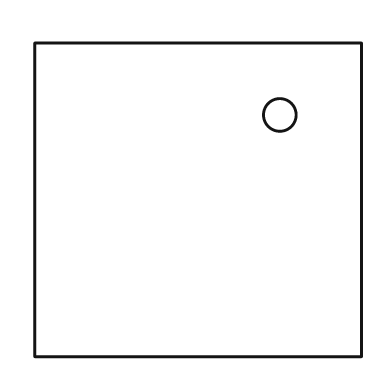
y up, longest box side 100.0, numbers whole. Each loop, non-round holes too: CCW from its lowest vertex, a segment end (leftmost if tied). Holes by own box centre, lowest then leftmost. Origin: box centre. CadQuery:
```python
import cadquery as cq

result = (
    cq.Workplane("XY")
    .moveTo(-50.0, -48.0)
    .lineTo(50.0, -48.0)
    .lineTo(50.0, 48.0)
    .lineTo(-50.0, 48.0)
    .close()
    .moveTo(25.0, 26.0)
    .circle(5.0)
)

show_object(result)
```